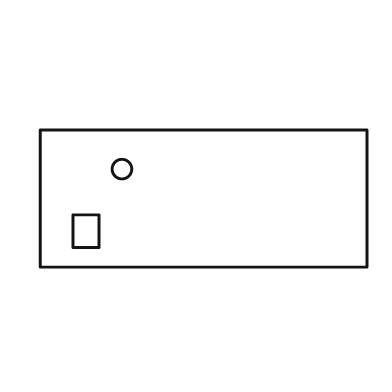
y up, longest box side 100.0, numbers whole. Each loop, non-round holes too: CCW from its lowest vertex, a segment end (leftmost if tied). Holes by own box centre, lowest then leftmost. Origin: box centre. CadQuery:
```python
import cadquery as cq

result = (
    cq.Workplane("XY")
    .moveTo(-50.0, -21.0)
    .lineTo(50.0, -21.0)
    .lineTo(50.0, 21.0)
    .lineTo(-50.0, 21.0)
    .close()
    .moveTo(-40.0, -15.0)
    .lineTo(-32.0, -15.0)
    .lineTo(-32.0, -5.0)
    .lineTo(-40.0, -5.0)
    .close()
    .moveTo(-25.0, 9.0)
    .circle(3.0)
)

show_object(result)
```